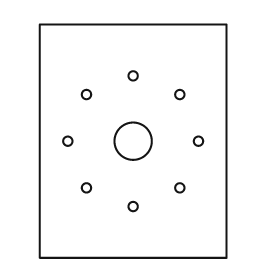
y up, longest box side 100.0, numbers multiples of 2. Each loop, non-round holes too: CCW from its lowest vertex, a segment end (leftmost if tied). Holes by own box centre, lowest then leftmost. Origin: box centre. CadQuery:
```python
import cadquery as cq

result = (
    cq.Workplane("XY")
    .moveTo(-40.0, -50.0)
    .lineTo(40.0, -50.0)
    .lineTo(40.0, 50.0)
    .lineTo(-40.0, 50.0)
    .close()
    .moveTo(0.0, -28.0)
    .circle(2.0)
    .moveTo(-20.0, -20.0)
    .circle(2.0)
    .moveTo(20.0, -20.0)
    .circle(2.0)
    .moveTo(-28.0, 0.0)
    .circle(2.0)
    .moveTo(0.0, 0.0)
    .circle(8.0)
    .moveTo(28.0, 0.0)
    .circle(2.0)
    .moveTo(-20.0, 20.0)
    .circle(2.0)
    .moveTo(20.0, 20.0)
    .circle(2.0)
    .moveTo(0.0, 28.0)
    .circle(2.0)
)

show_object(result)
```